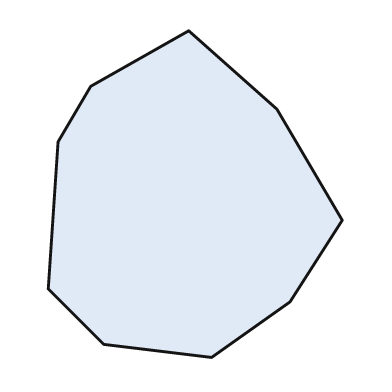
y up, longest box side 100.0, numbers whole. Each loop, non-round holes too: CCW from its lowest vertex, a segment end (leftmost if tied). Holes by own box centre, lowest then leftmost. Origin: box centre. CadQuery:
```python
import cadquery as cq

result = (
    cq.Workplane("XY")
    .moveTo(5.0, -50.0)
    .lineTo(29.0, -33.0)
    .lineTo(45.0, -8.0)
    .lineTo(25.0, 26.0)
    .lineTo(-2.0, 50.0)
    .lineTo(-32.0, 33.0)
    .lineTo(-42.0, 16.0)
    .lineTo(-45.0, -29.0)
    .lineTo(-28.0, -46.0)
    .close()
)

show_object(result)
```